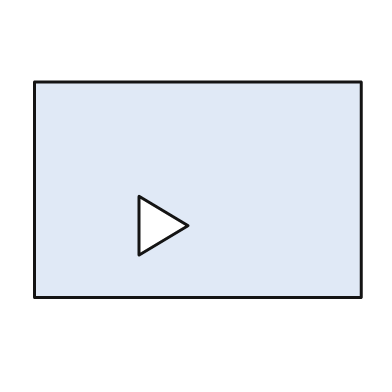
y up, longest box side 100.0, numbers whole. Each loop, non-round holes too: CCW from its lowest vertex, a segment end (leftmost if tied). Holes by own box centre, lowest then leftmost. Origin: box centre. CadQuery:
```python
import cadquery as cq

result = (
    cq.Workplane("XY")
    .moveTo(-50.0, -33.0)
    .lineTo(50.0, -33.0)
    .lineTo(50.0, 33.0)
    .lineTo(-50.0, 33.0)
    .close()
    .moveTo(-18.0, -20.0)
    .lineTo(-3.0, -11.0)
    .lineTo(-18.0, -2.0)
    .close()
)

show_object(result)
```